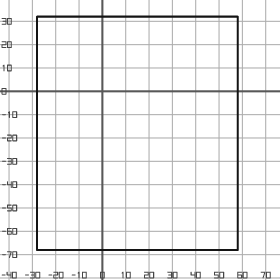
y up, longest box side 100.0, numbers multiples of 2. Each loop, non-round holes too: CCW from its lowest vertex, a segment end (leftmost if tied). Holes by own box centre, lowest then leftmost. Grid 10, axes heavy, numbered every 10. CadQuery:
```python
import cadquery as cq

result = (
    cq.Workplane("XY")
    .moveTo(-28.0, -68.0)
    .lineTo(58.0, -68.0)
    .lineTo(58.0, 32.0)
    .lineTo(-28.0, 32.0)
    .close()
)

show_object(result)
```